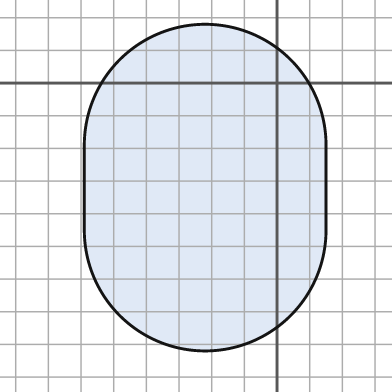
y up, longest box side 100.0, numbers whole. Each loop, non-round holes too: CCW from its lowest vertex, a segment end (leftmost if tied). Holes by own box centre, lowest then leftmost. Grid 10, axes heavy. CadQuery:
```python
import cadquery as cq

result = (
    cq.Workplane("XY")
    .moveTo(-59.0, -45.0)
    .threePointArc((-22.0, -82.0), (15.0, -45.0))
    .lineTo(15.0, -19.0)
    .threePointArc((-22.0, 18.0), (-59.0, -19.0))
    .close()
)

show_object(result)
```